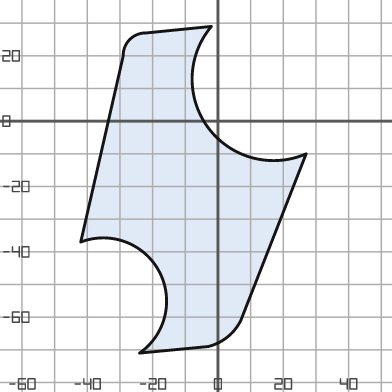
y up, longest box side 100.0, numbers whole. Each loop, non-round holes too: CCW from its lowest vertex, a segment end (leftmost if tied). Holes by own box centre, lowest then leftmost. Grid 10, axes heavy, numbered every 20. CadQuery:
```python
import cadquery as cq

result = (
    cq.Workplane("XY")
    .moveTo(-24.0, -71.0)
    .lineTo(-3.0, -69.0)
    .threePointArc((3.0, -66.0), (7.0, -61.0))
    .lineTo(27.0, -10.0)
    .threePointArc((-3.0, -2.0), (-2.0, 29.0))
    .lineTo(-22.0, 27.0)
    .threePointArc((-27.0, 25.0), (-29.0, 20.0))
    .lineTo(-42.0, -37.0)
    .threePointArc((-18.0, -46.0), (-24.0, -71.0))
    .close()
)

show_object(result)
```